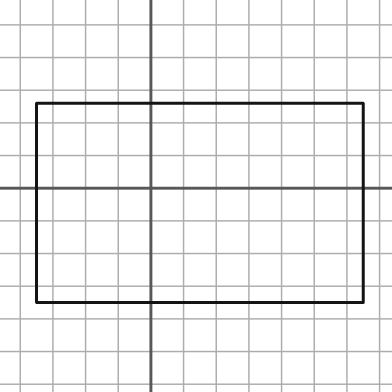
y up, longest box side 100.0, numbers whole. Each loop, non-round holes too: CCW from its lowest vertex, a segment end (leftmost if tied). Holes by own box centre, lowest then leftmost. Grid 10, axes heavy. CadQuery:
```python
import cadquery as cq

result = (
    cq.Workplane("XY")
    .moveTo(-35.0, -35.0)
    .lineTo(65.0, -35.0)
    .lineTo(65.0, 26.0)
    .lineTo(-35.0, 26.0)
    .close()
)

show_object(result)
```